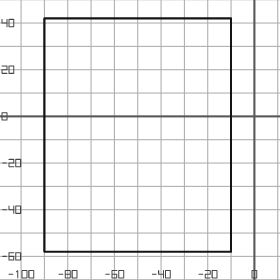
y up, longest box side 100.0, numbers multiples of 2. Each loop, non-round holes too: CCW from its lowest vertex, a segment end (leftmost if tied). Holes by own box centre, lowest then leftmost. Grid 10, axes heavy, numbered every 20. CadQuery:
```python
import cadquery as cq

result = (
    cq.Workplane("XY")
    .moveTo(-90.0, -58.0)
    .lineTo(-10.0, -58.0)
    .lineTo(-10.0, 42.0)
    .lineTo(-90.0, 42.0)
    .close()
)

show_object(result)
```